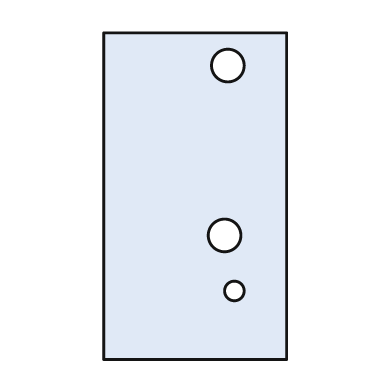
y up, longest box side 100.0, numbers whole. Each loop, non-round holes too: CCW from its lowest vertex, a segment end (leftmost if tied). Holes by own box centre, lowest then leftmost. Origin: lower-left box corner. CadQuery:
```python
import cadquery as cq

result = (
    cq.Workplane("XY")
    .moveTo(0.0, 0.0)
    .lineTo(56.0, 0.0)
    .lineTo(56.0, 100.0)
    .lineTo(0.0, 100.0)
    .close()
    .moveTo(40.0, 21.0)
    .circle(3.0)
    .moveTo(37.0, 38.0)
    .circle(5.0)
    .moveTo(38.0, 90.0)
    .circle(5.0)
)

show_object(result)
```